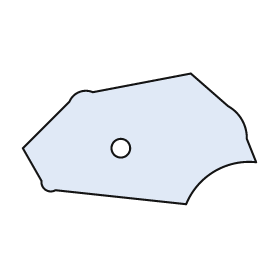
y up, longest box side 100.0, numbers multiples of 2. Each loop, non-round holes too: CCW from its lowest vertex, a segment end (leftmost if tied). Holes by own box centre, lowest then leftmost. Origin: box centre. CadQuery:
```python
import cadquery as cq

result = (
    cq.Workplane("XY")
    .moveTo(20.0, -28.0)
    .threePointArc((32.0, -14.0), (50.0, -10.0))
    .lineTo(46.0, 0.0)
    .threePointArc((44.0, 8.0), (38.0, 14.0))
    .lineTo(22.0, 28.0)
    .lineTo(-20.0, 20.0)
    .threePointArc((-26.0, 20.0), (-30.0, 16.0))
    .lineTo(-50.0, -4.0)
    .lineTo(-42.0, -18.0)
    .threePointArc((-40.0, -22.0), (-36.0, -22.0))
    .close()
    .moveTo(-8.0, -4.0)
    .circle(4.0)
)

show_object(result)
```